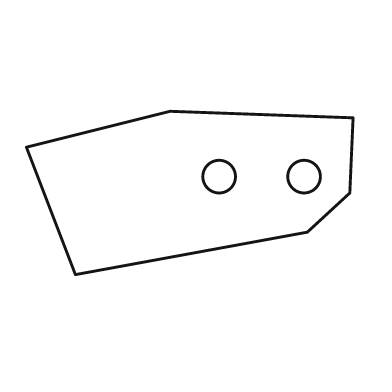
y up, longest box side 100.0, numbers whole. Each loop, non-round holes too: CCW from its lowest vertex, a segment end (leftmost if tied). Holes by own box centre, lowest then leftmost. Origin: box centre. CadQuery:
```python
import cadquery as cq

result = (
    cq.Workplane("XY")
    .moveTo(-35.0, -25.0)
    .lineTo(36.0, -12.0)
    .lineTo(49.0, 0.0)
    .lineTo(50.0, 23.0)
    .lineTo(-6.0, 25.0)
    .lineTo(-50.0, 14.0)
    .close()
    .moveTo(9.0, 5.0)
    .circle(5.0)
    .moveTo(35.0, 5.0)
    .circle(5.0)
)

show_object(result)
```